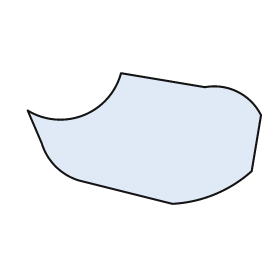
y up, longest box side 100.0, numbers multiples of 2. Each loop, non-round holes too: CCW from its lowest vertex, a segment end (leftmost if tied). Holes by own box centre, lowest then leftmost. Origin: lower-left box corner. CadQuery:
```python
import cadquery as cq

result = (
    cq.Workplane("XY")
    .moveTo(62.0, 0.0)
    .threePointArc((80.0, 4.0), (96.0, 14.0))
    .lineTo(100.0, 38.0)
    .threePointArc((90.0, 48.0), (76.0, 50.0))
    .lineTo(40.0, 56.0)
    .threePointArc((24.0, 38.0), (0.0, 40.0))
    .lineTo(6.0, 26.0)
    .threePointArc((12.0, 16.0), (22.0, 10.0))
    .close()
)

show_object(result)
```